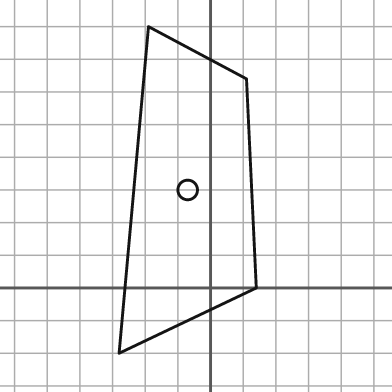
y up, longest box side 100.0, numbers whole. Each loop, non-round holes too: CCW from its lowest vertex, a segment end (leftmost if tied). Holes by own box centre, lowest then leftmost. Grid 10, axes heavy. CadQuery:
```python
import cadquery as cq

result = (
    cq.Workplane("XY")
    .moveTo(-28.0, -20.0)
    .lineTo(14.0, 0.0)
    .lineTo(11.0, 64.0)
    .lineTo(-19.0, 80.0)
    .close()
    .moveTo(-7.0, 30.0)
    .circle(3.0)
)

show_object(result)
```